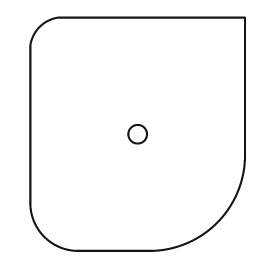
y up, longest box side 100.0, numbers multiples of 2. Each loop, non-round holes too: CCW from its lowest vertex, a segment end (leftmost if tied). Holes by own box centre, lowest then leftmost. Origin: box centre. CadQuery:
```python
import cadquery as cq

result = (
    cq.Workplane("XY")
    .moveTo(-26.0, -50.0)
    .lineTo(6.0, -50.0)
    .threePointArc((34.0, -38.0), (46.0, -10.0))
    .lineTo(46.0, 50.0)
    .lineTo(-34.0, 50.0)
    .threePointArc((-42.0, 46.0), (-46.0, 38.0))
    .lineTo(-46.0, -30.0)
    .threePointArc((-40.0, -44.0), (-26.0, -50.0))
    .close()
    .moveTo(0.0, 0.0)
    .circle(4.0)
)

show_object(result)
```